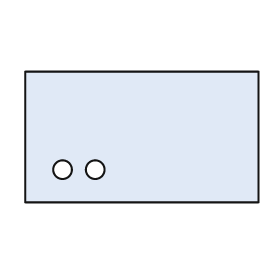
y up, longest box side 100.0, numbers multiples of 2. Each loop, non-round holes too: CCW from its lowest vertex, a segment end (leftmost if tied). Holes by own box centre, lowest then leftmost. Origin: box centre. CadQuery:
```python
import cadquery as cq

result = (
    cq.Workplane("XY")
    .moveTo(-50.0, -28.0)
    .lineTo(50.0, -28.0)
    .lineTo(50.0, 28.0)
    .lineTo(-50.0, 28.0)
    .close()
    .moveTo(-34.0, -14.0)
    .circle(4.0)
    .moveTo(-20.0, -14.0)
    .circle(4.0)
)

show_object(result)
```